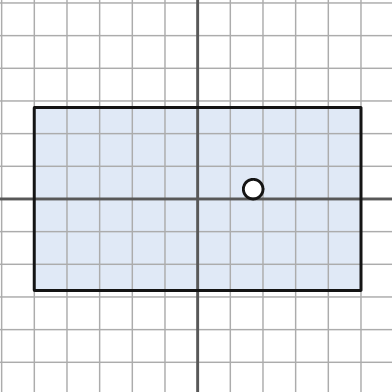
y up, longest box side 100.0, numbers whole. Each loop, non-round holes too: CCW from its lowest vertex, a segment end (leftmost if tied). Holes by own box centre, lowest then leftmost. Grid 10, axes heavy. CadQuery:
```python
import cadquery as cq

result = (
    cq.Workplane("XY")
    .moveTo(-50.0, -28.0)
    .lineTo(50.0, -28.0)
    .lineTo(50.0, 28.0)
    .lineTo(-50.0, 28.0)
    .close()
    .moveTo(17.0, 3.0)
    .circle(3.0)
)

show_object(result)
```